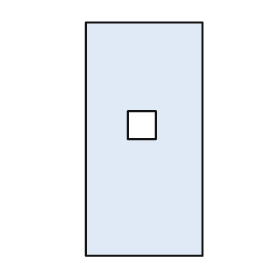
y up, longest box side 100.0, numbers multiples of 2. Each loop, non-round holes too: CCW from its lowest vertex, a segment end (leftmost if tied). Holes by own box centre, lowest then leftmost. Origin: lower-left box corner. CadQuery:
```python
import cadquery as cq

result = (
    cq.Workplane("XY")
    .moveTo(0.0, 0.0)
    .lineTo(50.0, 0.0)
    .lineTo(50.0, 100.0)
    .lineTo(0.0, 100.0)
    .close()
    .moveTo(18.0, 50.0)
    .lineTo(30.0, 50.0)
    .lineTo(30.0, 62.0)
    .lineTo(18.0, 62.0)
    .close()
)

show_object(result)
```